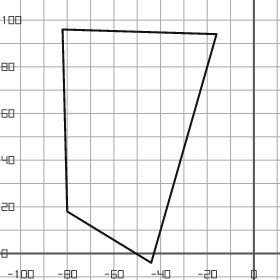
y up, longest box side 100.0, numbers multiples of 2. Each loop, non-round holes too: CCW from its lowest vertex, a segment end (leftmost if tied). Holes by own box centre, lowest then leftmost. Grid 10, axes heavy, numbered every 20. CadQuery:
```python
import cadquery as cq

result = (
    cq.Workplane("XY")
    .moveTo(-44.0, -4.0)
    .lineTo(-16.0, 94.0)
    .lineTo(-82.0, 96.0)
    .lineTo(-80.0, 18.0)
    .close()
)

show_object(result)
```